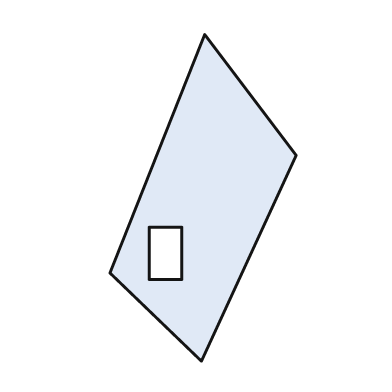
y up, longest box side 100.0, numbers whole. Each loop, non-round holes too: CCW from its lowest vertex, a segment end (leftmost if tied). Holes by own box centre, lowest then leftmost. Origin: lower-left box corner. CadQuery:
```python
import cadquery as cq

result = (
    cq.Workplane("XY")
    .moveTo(28.0, 0.0)
    .lineTo(57.0, 63.0)
    .lineTo(29.0, 100.0)
    .lineTo(0.0, 27.0)
    .close()
    .moveTo(12.0, 25.0)
    .lineTo(22.0, 25.0)
    .lineTo(22.0, 41.0)
    .lineTo(12.0, 41.0)
    .close()
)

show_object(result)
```